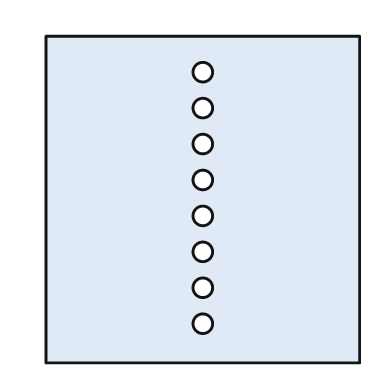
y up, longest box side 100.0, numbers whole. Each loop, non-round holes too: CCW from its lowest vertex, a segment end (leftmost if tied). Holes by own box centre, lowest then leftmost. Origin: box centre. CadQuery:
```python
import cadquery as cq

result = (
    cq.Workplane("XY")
    .moveTo(-48.0, -50.0)
    .lineTo(48.0, -50.0)
    .lineTo(48.0, 50.0)
    .lineTo(-48.0, 50.0)
    .close()
    .moveTo(0.0, -38.0)
    .circle(3.0)
    .moveTo(0.0, -27.0)
    .circle(3.0)
    .moveTo(0.0, -16.0)
    .circle(3.0)
    .moveTo(0.0, -5.0)
    .circle(3.0)
    .moveTo(0.0, 6.0)
    .circle(3.0)
    .moveTo(0.0, 17.0)
    .circle(3.0)
    .moveTo(0.0, 28.0)
    .circle(3.0)
    .moveTo(0.0, 39.0)
    .circle(3.0)
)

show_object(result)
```